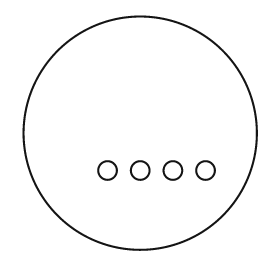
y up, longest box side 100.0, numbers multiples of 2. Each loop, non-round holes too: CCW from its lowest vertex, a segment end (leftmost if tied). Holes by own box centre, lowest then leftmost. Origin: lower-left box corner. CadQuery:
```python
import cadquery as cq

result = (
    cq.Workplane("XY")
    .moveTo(50.0, 50.0)
    .circle(50.0)
    .moveTo(36.0, 34.0)
    .circle(4.0)
    .moveTo(50.0, 34.0)
    .circle(4.0)
    .moveTo(64.0, 34.0)
    .circle(4.0)
    .moveTo(78.0, 34.0)
    .circle(4.0)
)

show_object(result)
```